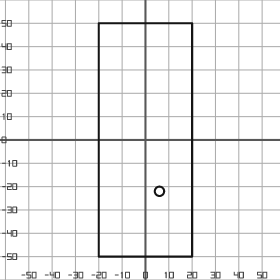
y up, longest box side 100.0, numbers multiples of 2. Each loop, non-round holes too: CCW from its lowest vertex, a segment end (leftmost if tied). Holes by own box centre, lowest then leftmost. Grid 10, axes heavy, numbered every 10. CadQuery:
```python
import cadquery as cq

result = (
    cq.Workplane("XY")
    .moveTo(-20.0, -50.0)
    .lineTo(20.0, -50.0)
    .lineTo(20.0, 50.0)
    .lineTo(-20.0, 50.0)
    .close()
    .moveTo(6.0, -22.0)
    .circle(2.0)
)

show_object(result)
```